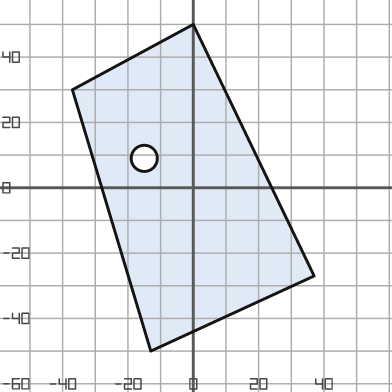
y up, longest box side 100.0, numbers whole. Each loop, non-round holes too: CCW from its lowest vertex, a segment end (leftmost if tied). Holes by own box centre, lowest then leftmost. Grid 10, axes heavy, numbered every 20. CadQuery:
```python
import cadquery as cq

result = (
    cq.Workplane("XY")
    .moveTo(-13.0, -50.0)
    .lineTo(37.0, -27.0)
    .lineTo(0.0, 50.0)
    .lineTo(-37.0, 30.0)
    .close()
    .moveTo(-15.0, 9.0)
    .circle(4.0)
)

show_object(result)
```